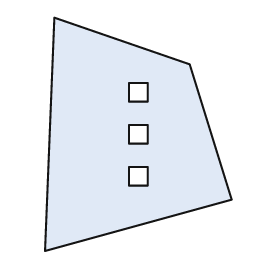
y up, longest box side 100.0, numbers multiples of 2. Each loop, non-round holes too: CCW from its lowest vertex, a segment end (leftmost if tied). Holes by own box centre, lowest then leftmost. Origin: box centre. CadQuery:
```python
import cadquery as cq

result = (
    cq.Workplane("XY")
    .moveTo(-40.0, -50.0)
    .lineTo(40.0, -28.0)
    .lineTo(22.0, 30.0)
    .lineTo(-36.0, 50.0)
    .close()
    .moveTo(-4.0, -22.0)
    .lineTo(4.0, -22.0)
    .lineTo(4.0, -14.0)
    .lineTo(-4.0, -14.0)
    .close()
    .moveTo(-4.0, -4.0)
    .lineTo(4.0, -4.0)
    .lineTo(4.0, 4.0)
    .lineTo(-4.0, 4.0)
    .close()
    .moveTo(-4.0, 14.0)
    .lineTo(4.0, 14.0)
    .lineTo(4.0, 22.0)
    .lineTo(-4.0, 22.0)
    .close()
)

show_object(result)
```